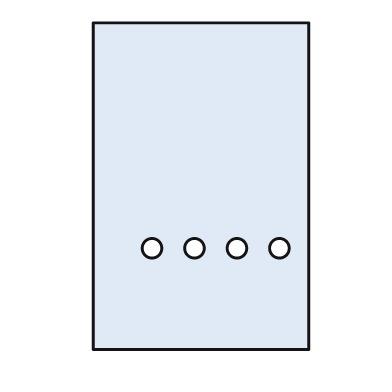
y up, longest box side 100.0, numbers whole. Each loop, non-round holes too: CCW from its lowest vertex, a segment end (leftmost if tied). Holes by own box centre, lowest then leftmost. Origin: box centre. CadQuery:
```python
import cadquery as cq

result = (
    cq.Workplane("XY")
    .moveTo(-33.0, -50.0)
    .lineTo(33.0, -50.0)
    .lineTo(33.0, 50.0)
    .lineTo(-33.0, 50.0)
    .close()
    .moveTo(-15.0, -19.0)
    .circle(3.0)
    .moveTo(-2.0, -19.0)
    .circle(3.0)
    .moveTo(11.0, -19.0)
    .circle(3.0)
    .moveTo(24.0, -19.0)
    .circle(3.0)
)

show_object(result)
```